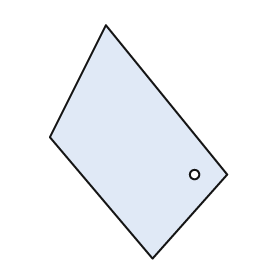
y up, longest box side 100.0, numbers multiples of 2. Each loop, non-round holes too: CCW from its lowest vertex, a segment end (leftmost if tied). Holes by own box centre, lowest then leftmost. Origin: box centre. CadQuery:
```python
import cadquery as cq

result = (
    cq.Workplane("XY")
    .moveTo(6.0, -50.0)
    .lineTo(38.0, -14.0)
    .lineTo(-14.0, 50.0)
    .lineTo(-38.0, 2.0)
    .close()
    .moveTo(24.0, -14.0)
    .circle(2.0)
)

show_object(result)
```